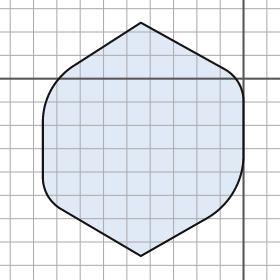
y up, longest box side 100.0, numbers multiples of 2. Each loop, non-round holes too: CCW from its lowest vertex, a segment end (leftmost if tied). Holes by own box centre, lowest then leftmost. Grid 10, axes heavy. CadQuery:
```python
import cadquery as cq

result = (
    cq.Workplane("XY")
    .moveTo(-44.0, -76.0)
    .lineTo(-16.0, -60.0)
    .threePointArc((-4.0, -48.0), (0.0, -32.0))
    .lineTo(0.0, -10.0)
    .threePointArc((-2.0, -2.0), (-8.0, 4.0))
    .lineTo(-44.0, 24.0)
    .lineTo(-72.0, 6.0)
    .threePointArc((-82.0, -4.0), (-86.0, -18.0))
    .lineTo(-86.0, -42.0)
    .threePointArc((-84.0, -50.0), (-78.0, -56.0))
    .close()
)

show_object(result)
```